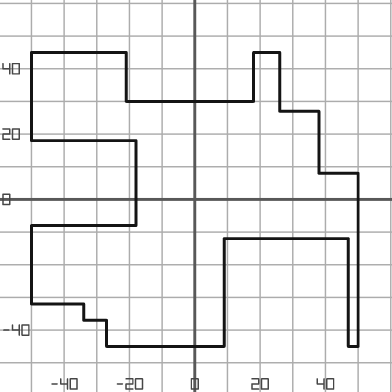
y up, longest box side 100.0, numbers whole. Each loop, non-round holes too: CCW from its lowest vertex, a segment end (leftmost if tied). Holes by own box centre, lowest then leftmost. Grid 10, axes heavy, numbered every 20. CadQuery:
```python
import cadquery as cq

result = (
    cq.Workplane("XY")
    .moveTo(-27.0, -45.0)
    .lineTo(9.0, -45.0)
    .lineTo(9.0, -12.0)
    .lineTo(47.0, -12.0)
    .lineTo(47.0, -45.0)
    .lineTo(50.0, -45.0)
    .lineTo(50.0, 8.0)
    .lineTo(38.0, 8.0)
    .lineTo(38.0, 27.0)
    .lineTo(26.0, 27.0)
    .lineTo(26.0, 45.0)
    .lineTo(18.0, 45.0)
    .lineTo(18.0, 30.0)
    .lineTo(-21.0, 30.0)
    .lineTo(-21.0, 45.0)
    .lineTo(-50.0, 45.0)
    .lineTo(-50.0, 18.0)
    .lineTo(-18.0, 18.0)
    .lineTo(-18.0, -8.0)
    .lineTo(-50.0, -8.0)
    .lineTo(-50.0, -32.0)
    .lineTo(-34.0, -32.0)
    .lineTo(-34.0, -37.0)
    .lineTo(-27.0, -37.0)
    .close()
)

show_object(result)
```